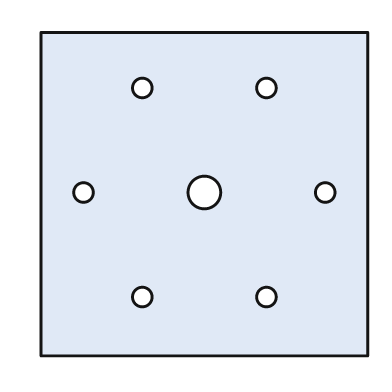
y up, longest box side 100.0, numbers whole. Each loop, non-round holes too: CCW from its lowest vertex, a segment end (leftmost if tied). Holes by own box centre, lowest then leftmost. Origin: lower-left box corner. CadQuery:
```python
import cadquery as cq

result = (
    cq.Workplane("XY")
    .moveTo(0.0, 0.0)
    .lineTo(100.0, 0.0)
    .lineTo(100.0, 99.0)
    .lineTo(0.0, 99.0)
    .close()
    .moveTo(31.0, 18.0)
    .circle(3.0)
    .moveTo(69.0, 18.0)
    .circle(3.0)
    .moveTo(13.0, 50.0)
    .circle(3.0)
    .moveTo(50.0, 50.0)
    .circle(5.0)
    .moveTo(87.0, 50.0)
    .circle(3.0)
    .moveTo(31.0, 82.0)
    .circle(3.0)
    .moveTo(69.0, 82.0)
    .circle(3.0)
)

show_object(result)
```